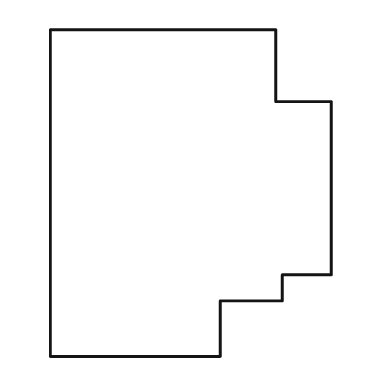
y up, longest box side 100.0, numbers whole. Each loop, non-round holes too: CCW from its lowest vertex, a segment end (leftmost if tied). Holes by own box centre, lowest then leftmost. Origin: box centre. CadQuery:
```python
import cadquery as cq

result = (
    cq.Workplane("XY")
    .moveTo(-43.0, -50.0)
    .lineTo(9.0, -50.0)
    .lineTo(9.0, -33.0)
    .lineTo(28.0, -33.0)
    .lineTo(28.0, -25.0)
    .lineTo(43.0, -25.0)
    .lineTo(43.0, 28.0)
    .lineTo(26.0, 28.0)
    .lineTo(26.0, 50.0)
    .lineTo(-43.0, 50.0)
    .close()
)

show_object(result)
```